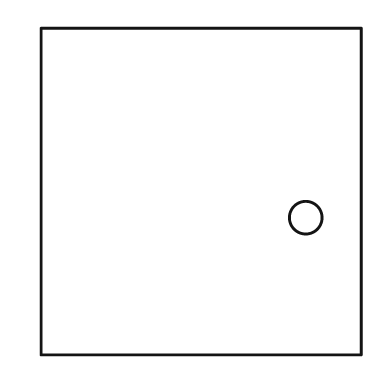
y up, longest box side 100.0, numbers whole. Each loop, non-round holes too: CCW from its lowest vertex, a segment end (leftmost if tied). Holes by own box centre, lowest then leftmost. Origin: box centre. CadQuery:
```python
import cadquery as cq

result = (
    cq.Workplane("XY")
    .moveTo(-49.0, -50.0)
    .lineTo(49.0, -50.0)
    .lineTo(49.0, 50.0)
    .lineTo(-49.0, 50.0)
    .close()
    .moveTo(32.0, -8.0)
    .circle(5.0)
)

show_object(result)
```